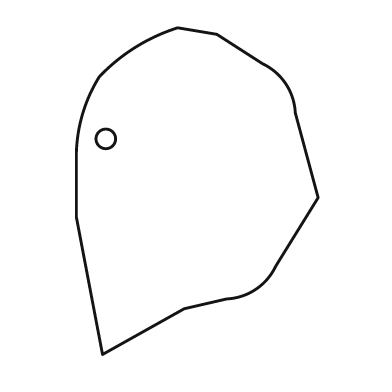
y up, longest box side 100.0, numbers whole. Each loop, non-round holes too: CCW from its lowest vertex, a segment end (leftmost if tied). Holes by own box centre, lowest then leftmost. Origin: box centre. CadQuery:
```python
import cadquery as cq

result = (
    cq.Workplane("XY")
    .moveTo(-29.0, -50.0)
    .lineTo(-4.0, -36.0)
    .lineTo(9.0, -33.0)
    .threePointArc((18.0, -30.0), (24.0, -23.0))
    .lineTo(37.0, -2.0)
    .lineTo(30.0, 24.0)
    .threePointArc((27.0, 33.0), (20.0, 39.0))
    .lineTo(6.0, 48.0)
    .lineTo(-6.0, 50.0)
    .threePointArc((-19.0, 44.0), (-30.0, 35.0))
    .threePointArc((-35.0, 24.0), (-37.0, 12.0))
    .lineTo(-37.0, -8.0)
    .close()
    .moveTo(-28.0, 16.0)
    .circle(3.0)
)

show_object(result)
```